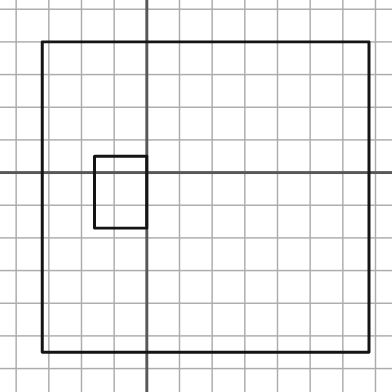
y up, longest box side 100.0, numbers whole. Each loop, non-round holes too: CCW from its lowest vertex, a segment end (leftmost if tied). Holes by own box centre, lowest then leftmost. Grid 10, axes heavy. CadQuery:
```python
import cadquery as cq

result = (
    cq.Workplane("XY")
    .moveTo(-32.0, -55.0)
    .lineTo(68.0, -55.0)
    .lineTo(68.0, 40.0)
    .lineTo(-32.0, 40.0)
    .close()
    .moveTo(-16.0, -17.0)
    .lineTo(0.0, -17.0)
    .lineTo(0.0, 5.0)
    .lineTo(-16.0, 5.0)
    .close()
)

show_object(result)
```